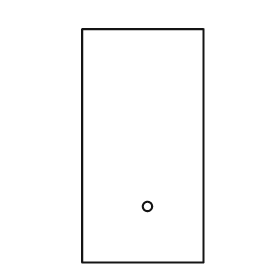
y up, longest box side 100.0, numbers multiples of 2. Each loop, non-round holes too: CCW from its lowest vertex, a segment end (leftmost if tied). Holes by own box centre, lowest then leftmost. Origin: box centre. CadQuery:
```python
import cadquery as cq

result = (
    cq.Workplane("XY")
    .moveTo(-26.0, -50.0)
    .lineTo(26.0, -50.0)
    .lineTo(26.0, 50.0)
    .lineTo(-26.0, 50.0)
    .close()
    .moveTo(2.0, -26.0)
    .circle(2.0)
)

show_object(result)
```